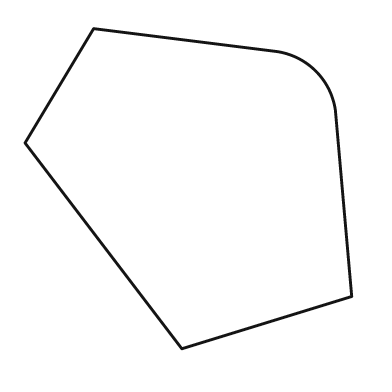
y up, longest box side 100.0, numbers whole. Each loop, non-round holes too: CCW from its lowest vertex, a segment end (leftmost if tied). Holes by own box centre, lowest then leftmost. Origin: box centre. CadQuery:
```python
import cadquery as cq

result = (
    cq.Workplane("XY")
    .moveTo(-2.0, -49.0)
    .lineTo(50.0, -33.0)
    .lineTo(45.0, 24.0)
    .threePointArc((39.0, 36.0), (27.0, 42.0))
    .lineTo(-29.0, 49.0)
    .lineTo(-50.0, 14.0)
    .close()
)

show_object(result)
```